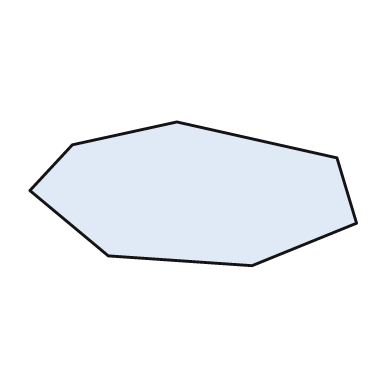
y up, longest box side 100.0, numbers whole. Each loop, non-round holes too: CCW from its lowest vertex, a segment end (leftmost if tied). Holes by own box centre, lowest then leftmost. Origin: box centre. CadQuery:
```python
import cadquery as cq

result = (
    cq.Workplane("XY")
    .moveTo(18.0, -22.0)
    .lineTo(50.0, -9.0)
    .lineTo(44.0, 11.0)
    .lineTo(-5.0, 22.0)
    .lineTo(-37.0, 15.0)
    .lineTo(-50.0, 1.0)
    .lineTo(-26.0, -19.0)
    .close()
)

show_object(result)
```